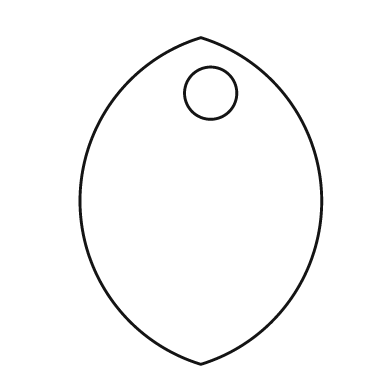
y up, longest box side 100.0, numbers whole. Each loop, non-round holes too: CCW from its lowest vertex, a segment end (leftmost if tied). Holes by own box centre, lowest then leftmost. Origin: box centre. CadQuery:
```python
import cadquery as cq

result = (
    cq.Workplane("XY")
    .moveTo(0.0, -50.0)
    .threePointArc((37.0, 0.0), (0.0, 50.0))
    .threePointArc((-37.0, 0.0), (0.0, -50.0))
    .close()
    .moveTo(3.0, 33.0)
    .circle(8.0)
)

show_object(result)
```